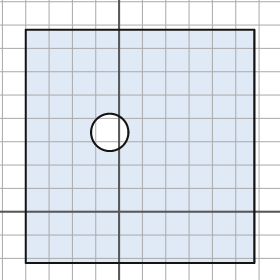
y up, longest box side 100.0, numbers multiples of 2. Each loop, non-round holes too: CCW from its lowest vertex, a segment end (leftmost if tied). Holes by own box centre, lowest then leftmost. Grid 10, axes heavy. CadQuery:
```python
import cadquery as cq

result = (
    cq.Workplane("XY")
    .moveTo(-40.0, -22.0)
    .lineTo(58.0, -22.0)
    .lineTo(58.0, 78.0)
    .lineTo(-40.0, 78.0)
    .close()
    .moveTo(-4.0, 34.0)
    .circle(8.0)
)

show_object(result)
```